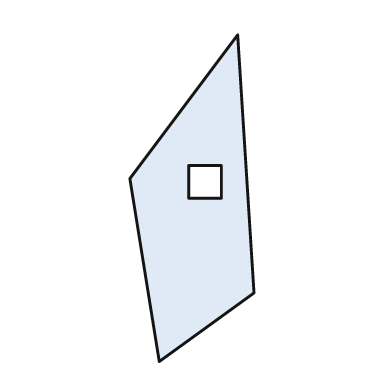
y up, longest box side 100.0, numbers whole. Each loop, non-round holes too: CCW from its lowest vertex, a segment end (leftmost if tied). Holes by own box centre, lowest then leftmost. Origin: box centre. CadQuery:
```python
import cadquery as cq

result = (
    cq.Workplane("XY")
    .moveTo(-10.0, -50.0)
    .lineTo(19.0, -29.0)
    .lineTo(14.0, 50.0)
    .lineTo(-19.0, 6.0)
    .close()
    .moveTo(-1.0, 0.0)
    .lineTo(9.0, 0.0)
    .lineTo(9.0, 10.0)
    .lineTo(-1.0, 10.0)
    .close()
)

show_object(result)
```